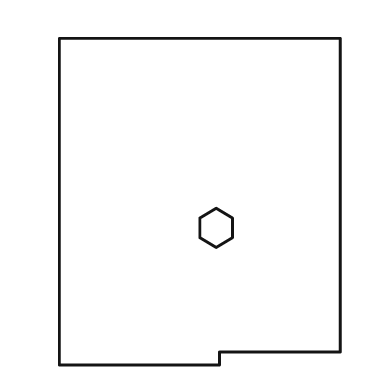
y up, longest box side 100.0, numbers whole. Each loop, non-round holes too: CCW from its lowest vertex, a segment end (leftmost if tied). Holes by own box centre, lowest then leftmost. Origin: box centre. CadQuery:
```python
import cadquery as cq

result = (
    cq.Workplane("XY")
    .moveTo(-43.0, -50.0)
    .lineTo(6.0, -50.0)
    .lineTo(6.0, -46.0)
    .lineTo(43.0, -46.0)
    .lineTo(43.0, 50.0)
    .lineTo(-43.0, 50.0)
    .close()
    .moveTo(5.0, -14.0)
    .lineTo(10.0, -11.0)
    .lineTo(10.0, -5.0)
    .lineTo(5.0, -2.0)
    .lineTo(0.0, -5.0)
    .lineTo(0.0, -11.0)
    .close()
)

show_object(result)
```